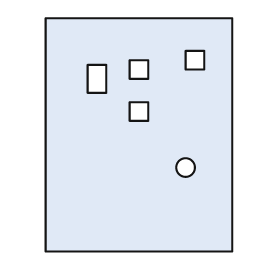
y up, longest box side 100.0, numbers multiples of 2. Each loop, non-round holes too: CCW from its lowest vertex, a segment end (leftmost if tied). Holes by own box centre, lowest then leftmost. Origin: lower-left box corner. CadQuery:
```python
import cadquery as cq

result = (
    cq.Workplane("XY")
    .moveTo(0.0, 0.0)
    .lineTo(80.0, 0.0)
    .lineTo(80.0, 100.0)
    .lineTo(0.0, 100.0)
    .close()
    .moveTo(60.0, 36.0)
    .circle(4.0)
    .moveTo(36.0, 56.0)
    .lineTo(44.0, 56.0)
    .lineTo(44.0, 64.0)
    .lineTo(36.0, 64.0)
    .close()
    .moveTo(18.0, 68.0)
    .lineTo(26.0, 68.0)
    .lineTo(26.0, 80.0)
    .lineTo(18.0, 80.0)
    .close()
    .moveTo(36.0, 74.0)
    .lineTo(44.0, 74.0)
    .lineTo(44.0, 82.0)
    .lineTo(36.0, 82.0)
    .close()
    .moveTo(60.0, 78.0)
    .lineTo(68.0, 78.0)
    .lineTo(68.0, 86.0)
    .lineTo(60.0, 86.0)
    .close()
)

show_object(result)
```